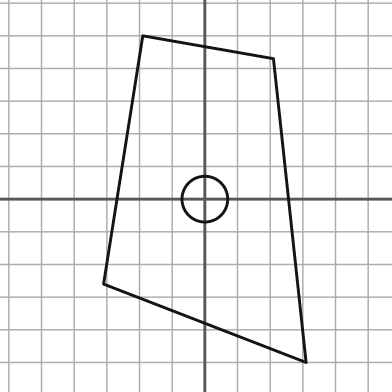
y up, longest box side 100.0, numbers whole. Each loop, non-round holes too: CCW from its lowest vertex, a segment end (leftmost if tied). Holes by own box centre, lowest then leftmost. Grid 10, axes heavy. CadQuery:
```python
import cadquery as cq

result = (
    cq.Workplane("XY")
    .moveTo(31.0, -50.0)
    .lineTo(21.0, 43.0)
    .lineTo(-19.0, 50.0)
    .lineTo(-31.0, -26.0)
    .close()
    .moveTo(0.0, 0.0)
    .circle(7.0)
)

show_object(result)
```